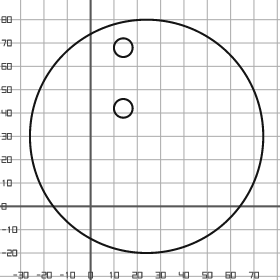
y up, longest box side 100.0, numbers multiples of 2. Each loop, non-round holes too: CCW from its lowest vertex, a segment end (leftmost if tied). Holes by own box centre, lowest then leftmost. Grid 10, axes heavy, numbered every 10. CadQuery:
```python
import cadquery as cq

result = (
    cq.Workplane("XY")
    .moveTo(24.0, 30.0)
    .circle(50.0)
    .moveTo(14.0, 42.0)
    .circle(4.0)
    .moveTo(14.0, 68.0)
    .circle(4.0)
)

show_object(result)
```